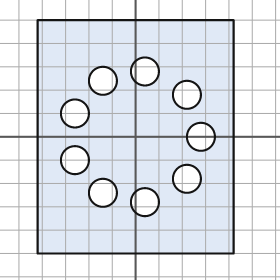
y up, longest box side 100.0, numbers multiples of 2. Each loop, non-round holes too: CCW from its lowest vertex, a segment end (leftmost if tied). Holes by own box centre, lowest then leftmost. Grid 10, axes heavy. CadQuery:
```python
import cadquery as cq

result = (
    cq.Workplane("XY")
    .moveTo(-42.0, -50.0)
    .lineTo(42.0, -50.0)
    .lineTo(42.0, 50.0)
    .lineTo(-42.0, 50.0)
    .close()
    .moveTo(4.0, -28.0)
    .circle(6.0)
    .moveTo(-14.0, -24.0)
    .circle(6.0)
    .moveTo(22.0, -18.0)
    .circle(6.0)
    .moveTo(-26.0, -10.0)
    .circle(6.0)
    .moveTo(28.0, 0.0)
    .circle(6.0)
    .moveTo(-26.0, 10.0)
    .circle(6.0)
    .moveTo(22.0, 18.0)
    .circle(6.0)
    .moveTo(-14.0, 24.0)
    .circle(6.0)
    .moveTo(4.0, 28.0)
    .circle(6.0)
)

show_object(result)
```